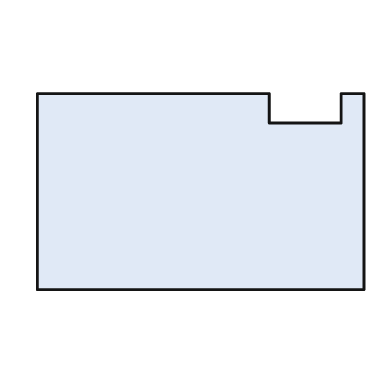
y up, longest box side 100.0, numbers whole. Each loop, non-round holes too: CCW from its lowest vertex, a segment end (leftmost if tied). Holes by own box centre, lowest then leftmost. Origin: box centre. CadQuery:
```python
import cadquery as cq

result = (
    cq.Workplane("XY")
    .moveTo(-50.0, -30.0)
    .lineTo(50.0, -30.0)
    .lineTo(50.0, 30.0)
    .lineTo(43.0, 30.0)
    .lineTo(43.0, 21.0)
    .lineTo(21.0, 21.0)
    .lineTo(21.0, 30.0)
    .lineTo(-50.0, 30.0)
    .close()
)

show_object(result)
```